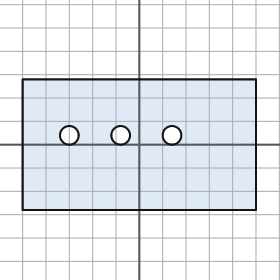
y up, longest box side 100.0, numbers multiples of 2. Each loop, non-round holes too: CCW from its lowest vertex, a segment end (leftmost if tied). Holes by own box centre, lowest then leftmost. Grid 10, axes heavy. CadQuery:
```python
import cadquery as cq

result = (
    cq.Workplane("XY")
    .moveTo(-50.0, -28.0)
    .lineTo(50.0, -28.0)
    .lineTo(50.0, 28.0)
    .lineTo(-50.0, 28.0)
    .close()
    .moveTo(-30.0, 4.0)
    .circle(4.0)
    .moveTo(-8.0, 4.0)
    .circle(4.0)
    .moveTo(14.0, 4.0)
    .circle(4.0)
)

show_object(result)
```